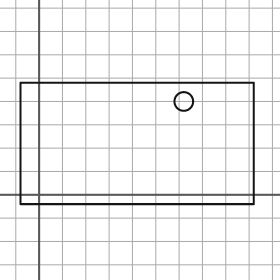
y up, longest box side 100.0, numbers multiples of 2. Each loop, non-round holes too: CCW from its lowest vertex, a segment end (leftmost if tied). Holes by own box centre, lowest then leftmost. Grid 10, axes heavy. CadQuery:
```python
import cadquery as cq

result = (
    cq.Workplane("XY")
    .moveTo(-8.0, -4.0)
    .lineTo(92.0, -4.0)
    .lineTo(92.0, 48.0)
    .lineTo(-8.0, 48.0)
    .close()
    .moveTo(62.0, 40.0)
    .circle(4.0)
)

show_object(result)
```